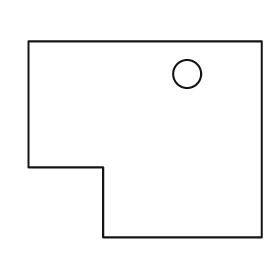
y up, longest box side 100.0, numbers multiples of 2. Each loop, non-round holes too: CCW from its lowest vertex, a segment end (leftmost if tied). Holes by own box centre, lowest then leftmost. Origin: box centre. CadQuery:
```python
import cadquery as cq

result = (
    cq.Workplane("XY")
    .moveTo(-18.0, -42.0)
    .lineTo(50.0, -42.0)
    .lineTo(50.0, 42.0)
    .lineTo(-50.0, 42.0)
    .lineTo(-50.0, -12.0)
    .lineTo(-18.0, -12.0)
    .close()
    .moveTo(18.0, 28.0)
    .circle(6.0)
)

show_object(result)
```